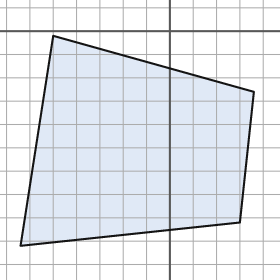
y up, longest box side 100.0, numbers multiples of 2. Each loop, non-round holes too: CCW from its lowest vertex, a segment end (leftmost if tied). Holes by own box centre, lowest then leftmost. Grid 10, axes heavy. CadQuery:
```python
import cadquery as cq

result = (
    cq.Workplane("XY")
    .moveTo(-64.0, -92.0)
    .lineTo(30.0, -82.0)
    .lineTo(36.0, -26.0)
    .lineTo(-50.0, -2.0)
    .close()
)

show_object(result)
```